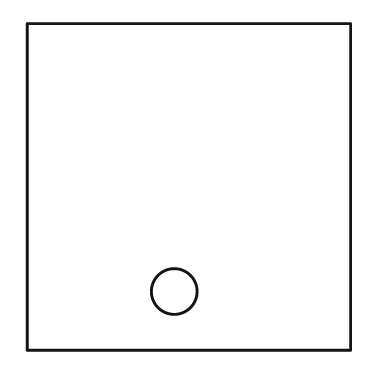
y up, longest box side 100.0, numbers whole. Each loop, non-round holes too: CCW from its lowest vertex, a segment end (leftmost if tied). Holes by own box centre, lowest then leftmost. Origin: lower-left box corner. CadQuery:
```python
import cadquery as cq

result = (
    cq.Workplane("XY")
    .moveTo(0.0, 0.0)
    .lineTo(99.0, 0.0)
    .lineTo(99.0, 100.0)
    .lineTo(0.0, 100.0)
    .close()
    .moveTo(45.0, 18.0)
    .circle(7.0)
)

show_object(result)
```